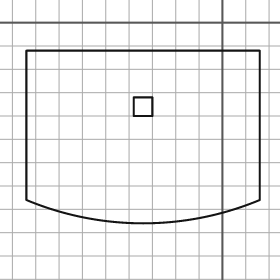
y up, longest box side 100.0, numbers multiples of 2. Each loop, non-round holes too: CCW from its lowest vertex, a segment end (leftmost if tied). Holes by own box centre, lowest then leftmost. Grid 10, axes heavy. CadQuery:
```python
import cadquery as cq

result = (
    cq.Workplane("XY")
    .moveTo(-84.0, -76.0)
    .threePointArc((-34.0, -86.0), (16.0, -76.0))
    .lineTo(16.0, -12.0)
    .lineTo(-84.0, -12.0)
    .close()
    .moveTo(-38.0, -40.0)
    .lineTo(-30.0, -40.0)
    .lineTo(-30.0, -32.0)
    .lineTo(-38.0, -32.0)
    .close()
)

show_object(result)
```